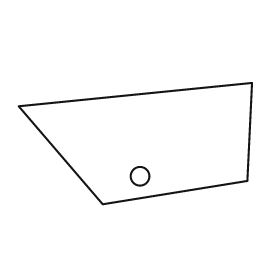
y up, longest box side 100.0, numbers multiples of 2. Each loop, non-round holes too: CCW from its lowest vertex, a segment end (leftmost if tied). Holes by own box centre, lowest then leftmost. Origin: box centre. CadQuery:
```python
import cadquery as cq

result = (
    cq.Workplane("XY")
    .moveTo(-14.0, -26.0)
    .lineTo(48.0, -16.0)
    .lineTo(50.0, 26.0)
    .lineTo(-50.0, 16.0)
    .close()
    .moveTo(2.0, -14.0)
    .circle(4.0)
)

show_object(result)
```